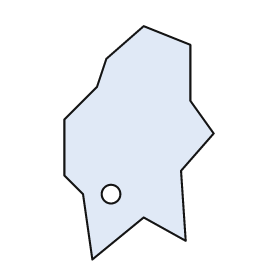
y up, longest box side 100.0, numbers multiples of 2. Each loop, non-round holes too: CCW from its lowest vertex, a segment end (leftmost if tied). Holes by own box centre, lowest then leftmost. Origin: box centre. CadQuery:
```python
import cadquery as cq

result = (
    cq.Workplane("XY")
    .moveTo(-20.0, -50.0)
    .lineTo(2.0, -32.0)
    .lineTo(20.0, -42.0)
    .lineTo(18.0, -12.0)
    .lineTo(32.0, 4.0)
    .lineTo(22.0, 18.0)
    .lineTo(22.0, 42.0)
    .lineTo(2.0, 50.0)
    .lineTo(-14.0, 36.0)
    .lineTo(-18.0, 24.0)
    .lineTo(-32.0, 10.0)
    .lineTo(-32.0, -14.0)
    .lineTo(-24.0, -22.0)
    .close()
    .moveTo(-12.0, -22.0)
    .circle(4.0)
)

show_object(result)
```